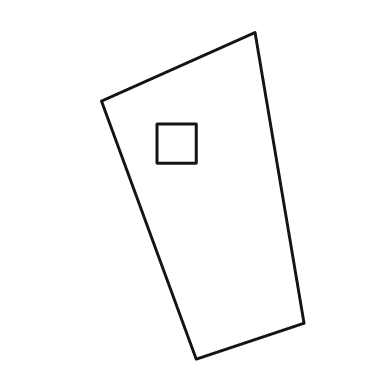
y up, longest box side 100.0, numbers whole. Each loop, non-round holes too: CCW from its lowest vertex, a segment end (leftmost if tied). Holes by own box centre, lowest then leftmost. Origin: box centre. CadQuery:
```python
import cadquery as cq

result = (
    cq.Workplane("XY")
    .moveTo(-2.0, -50.0)
    .lineTo(31.0, -39.0)
    .lineTo(16.0, 50.0)
    .lineTo(-31.0, 29.0)
    .close()
    .moveTo(-14.0, 10.0)
    .lineTo(-2.0, 10.0)
    .lineTo(-2.0, 22.0)
    .lineTo(-14.0, 22.0)
    .close()
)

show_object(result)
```